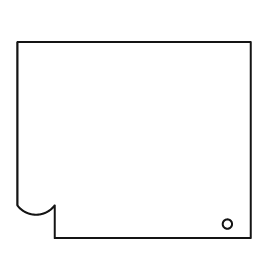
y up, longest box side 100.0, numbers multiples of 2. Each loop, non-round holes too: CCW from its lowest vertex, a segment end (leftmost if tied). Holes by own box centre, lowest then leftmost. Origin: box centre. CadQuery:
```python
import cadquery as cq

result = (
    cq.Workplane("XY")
    .moveTo(-34.0, -42.0)
    .lineTo(50.0, -42.0)
    .lineTo(50.0, 42.0)
    .lineTo(-50.0, 42.0)
    .lineTo(-50.0, -28.0)
    .threePointArc((-42.0, -32.0), (-34.0, -28.0))
    .close()
    .moveTo(40.0, -36.0)
    .circle(2.0)
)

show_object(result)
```